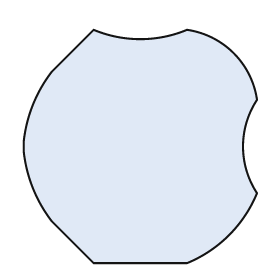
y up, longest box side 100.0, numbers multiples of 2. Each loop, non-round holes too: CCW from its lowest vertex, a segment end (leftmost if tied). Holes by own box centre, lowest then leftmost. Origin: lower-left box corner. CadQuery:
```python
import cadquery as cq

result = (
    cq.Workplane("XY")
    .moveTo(30.0, 0.0)
    .lineTo(70.0, 0.0)
    .threePointArc((88.0, 12.0), (100.0, 30.0))
    .threePointArc((94.0, 50.0), (100.0, 70.0))
    .threePointArc((90.0, 90.0), (70.0, 100.0))
    .threePointArc((50.0, 96.0), (30.0, 100.0))
    .lineTo(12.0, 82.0)
    .threePointArc((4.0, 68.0), (0.0, 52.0))
    .lineTo(0.0, 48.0)
    .threePointArc((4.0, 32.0), (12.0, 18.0))
    .close()
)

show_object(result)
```